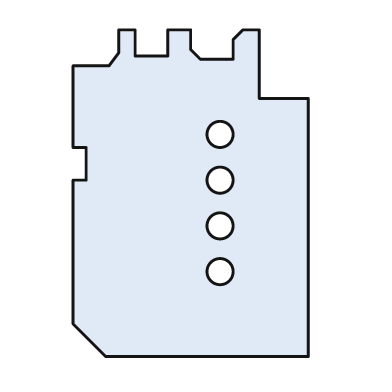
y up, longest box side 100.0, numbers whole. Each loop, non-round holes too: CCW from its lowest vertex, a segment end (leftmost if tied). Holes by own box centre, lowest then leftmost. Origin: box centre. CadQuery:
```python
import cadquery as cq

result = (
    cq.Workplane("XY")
    .moveTo(-26.0, -50.0)
    .lineTo(36.0, -50.0)
    .lineTo(36.0, 29.0)
    .lineTo(21.0, 29.0)
    .lineTo(21.0, 50.0)
    .lineTo(16.0, 50.0)
    .lineTo(13.0, 47.0)
    .lineTo(13.0, 41.0)
    .lineTo(3.0, 41.0)
    .lineTo(0.0, 44.0)
    .lineTo(0.0, 50.0)
    .lineTo(-7.0, 50.0)
    .lineTo(-7.0, 42.0)
    .lineTo(-17.0, 42.0)
    .lineTo(-17.0, 50.0)
    .lineTo(-22.0, 50.0)
    .lineTo(-22.0, 43.0)
    .lineTo(-25.0, 39.0)
    .lineTo(-36.0, 39.0)
    .lineTo(-36.0, 14.0)
    .lineTo(-32.0, 14.0)
    .lineTo(-32.0, 4.0)
    .lineTo(-36.0, 4.0)
    .lineTo(-36.0, -40.0)
    .close()
    .moveTo(9.0, -24.0)
    .circle(4.0)
    .moveTo(9.0, -10.0)
    .circle(4.0)
    .moveTo(9.0, 4.0)
    .circle(4.0)
    .moveTo(9.0, 18.0)
    .circle(4.0)
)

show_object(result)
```